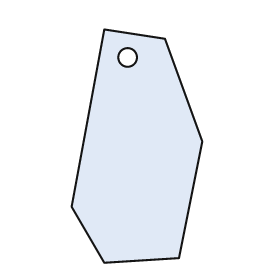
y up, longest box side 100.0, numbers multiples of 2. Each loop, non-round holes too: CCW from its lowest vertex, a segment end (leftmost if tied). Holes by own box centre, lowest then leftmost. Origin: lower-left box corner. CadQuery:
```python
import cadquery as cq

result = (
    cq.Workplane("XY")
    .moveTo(14.0, 0.0)
    .lineTo(46.0, 2.0)
    .lineTo(56.0, 52.0)
    .lineTo(40.0, 96.0)
    .lineTo(14.0, 100.0)
    .lineTo(0.0, 24.0)
    .close()
    .moveTo(24.0, 88.0)
    .circle(4.0)
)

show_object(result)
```